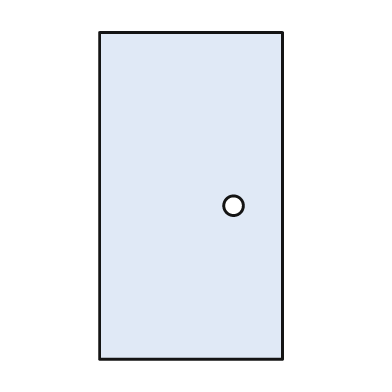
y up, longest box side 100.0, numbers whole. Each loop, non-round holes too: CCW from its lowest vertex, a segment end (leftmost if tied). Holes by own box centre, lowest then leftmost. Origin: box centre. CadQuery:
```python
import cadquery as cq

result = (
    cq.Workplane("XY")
    .moveTo(-28.0, -50.0)
    .lineTo(28.0, -50.0)
    .lineTo(28.0, 50.0)
    .lineTo(-28.0, 50.0)
    .close()
    .moveTo(13.0, -3.0)
    .circle(3.0)
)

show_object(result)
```